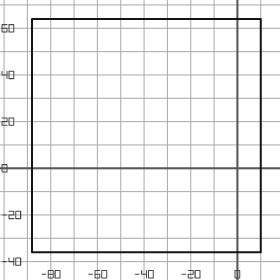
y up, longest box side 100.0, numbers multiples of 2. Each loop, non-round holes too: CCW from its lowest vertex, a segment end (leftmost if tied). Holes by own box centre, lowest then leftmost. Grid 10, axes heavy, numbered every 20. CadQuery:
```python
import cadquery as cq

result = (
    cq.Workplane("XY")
    .moveTo(-88.0, -36.0)
    .lineTo(10.0, -36.0)
    .lineTo(10.0, 64.0)
    .lineTo(-88.0, 64.0)
    .close()
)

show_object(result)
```